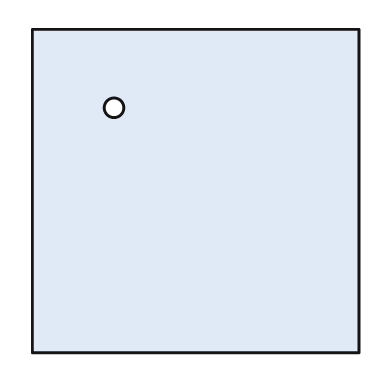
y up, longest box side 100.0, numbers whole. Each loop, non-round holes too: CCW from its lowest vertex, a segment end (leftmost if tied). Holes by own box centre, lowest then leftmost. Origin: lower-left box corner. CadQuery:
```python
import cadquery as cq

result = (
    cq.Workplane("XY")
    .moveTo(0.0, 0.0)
    .lineTo(100.0, 0.0)
    .lineTo(100.0, 99.0)
    .lineTo(0.0, 99.0)
    .close()
    .moveTo(25.0, 75.0)
    .circle(3.0)
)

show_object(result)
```